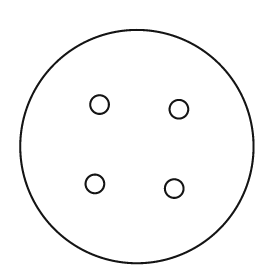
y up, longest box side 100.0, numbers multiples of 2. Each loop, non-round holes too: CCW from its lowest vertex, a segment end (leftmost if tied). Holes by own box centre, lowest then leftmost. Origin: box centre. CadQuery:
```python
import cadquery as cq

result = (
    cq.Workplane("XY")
    .moveTo(0.0, 0.0)
    .circle(50.0)
    .moveTo(16.0, -18.0)
    .circle(4.0)
    .moveTo(-18.0, -16.0)
    .circle(4.0)
    .moveTo(18.0, 16.0)
    .circle(4.0)
    .moveTo(-16.0, 18.0)
    .circle(4.0)
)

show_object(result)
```